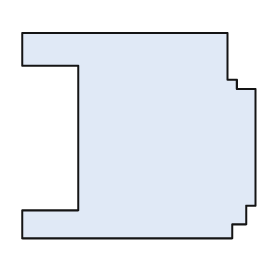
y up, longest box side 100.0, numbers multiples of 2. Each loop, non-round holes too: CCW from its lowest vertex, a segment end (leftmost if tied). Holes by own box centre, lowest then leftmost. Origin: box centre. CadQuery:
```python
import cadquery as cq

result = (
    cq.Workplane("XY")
    .moveTo(-50.0, -44.0)
    .lineTo(40.0, -44.0)
    .lineTo(40.0, -38.0)
    .lineTo(46.0, -38.0)
    .lineTo(46.0, -30.0)
    .lineTo(50.0, -30.0)
    .lineTo(50.0, 20.0)
    .lineTo(42.0, 20.0)
    .lineTo(42.0, 24.0)
    .lineTo(38.0, 24.0)
    .lineTo(38.0, 44.0)
    .lineTo(-50.0, 44.0)
    .lineTo(-50.0, 30.0)
    .lineTo(-26.0, 30.0)
    .lineTo(-26.0, -32.0)
    .lineTo(-50.0, -32.0)
    .close()
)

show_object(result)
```